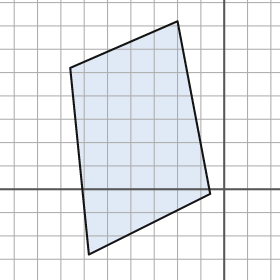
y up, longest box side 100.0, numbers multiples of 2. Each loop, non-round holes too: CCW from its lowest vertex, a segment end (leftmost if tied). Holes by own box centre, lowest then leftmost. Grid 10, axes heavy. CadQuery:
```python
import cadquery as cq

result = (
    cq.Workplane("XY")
    .moveTo(-58.0, -28.0)
    .lineTo(-6.0, -2.0)
    .lineTo(-20.0, 72.0)
    .lineTo(-66.0, 52.0)
    .close()
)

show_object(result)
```